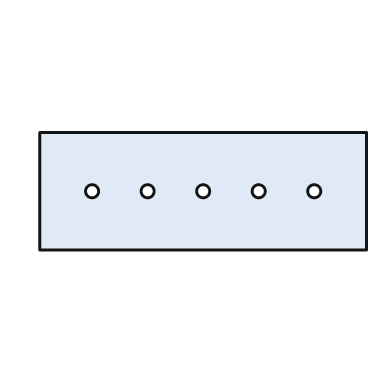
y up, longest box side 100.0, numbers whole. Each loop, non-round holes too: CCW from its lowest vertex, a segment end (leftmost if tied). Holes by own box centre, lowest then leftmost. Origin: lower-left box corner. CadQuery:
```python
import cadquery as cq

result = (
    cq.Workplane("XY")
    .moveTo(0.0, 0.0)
    .lineTo(100.0, 0.0)
    .lineTo(100.0, 36.0)
    .lineTo(0.0, 36.0)
    .close()
    .moveTo(16.0, 18.0)
    .circle(2.0)
    .moveTo(33.0, 18.0)
    .circle(2.0)
    .moveTo(50.0, 18.0)
    .circle(2.0)
    .moveTo(67.0, 18.0)
    .circle(2.0)
    .moveTo(84.0, 18.0)
    .circle(2.0)
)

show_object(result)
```